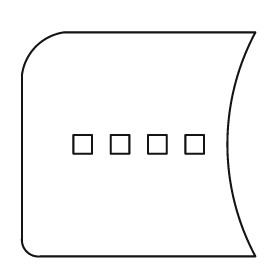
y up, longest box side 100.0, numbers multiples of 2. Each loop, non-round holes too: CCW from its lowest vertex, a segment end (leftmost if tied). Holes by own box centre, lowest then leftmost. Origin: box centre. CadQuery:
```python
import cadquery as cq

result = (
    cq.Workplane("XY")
    .moveTo(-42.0, -48.0)
    .lineTo(50.0, -48.0)
    .threePointArc((38.0, 0.0), (50.0, 48.0))
    .lineTo(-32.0, 48.0)
    .threePointArc((-44.0, 42.0), (-50.0, 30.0))
    .lineTo(-50.0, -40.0)
    .threePointArc((-48.0, -46.0), (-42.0, -48.0))
    .close()
    .moveTo(-28.0, -4.0)
    .lineTo(-20.0, -4.0)
    .lineTo(-20.0, 4.0)
    .lineTo(-28.0, 4.0)
    .close()
    .moveTo(-12.0, -4.0)
    .lineTo(-4.0, -4.0)
    .lineTo(-4.0, 4.0)
    .lineTo(-12.0, 4.0)
    .close()
    .moveTo(4.0, -4.0)
    .lineTo(12.0, -4.0)
    .lineTo(12.0, 4.0)
    .lineTo(4.0, 4.0)
    .close()
    .moveTo(20.0, -4.0)
    .lineTo(28.0, -4.0)
    .lineTo(28.0, 4.0)
    .lineTo(20.0, 4.0)
    .close()
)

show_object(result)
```